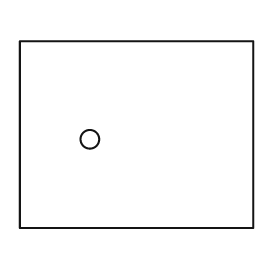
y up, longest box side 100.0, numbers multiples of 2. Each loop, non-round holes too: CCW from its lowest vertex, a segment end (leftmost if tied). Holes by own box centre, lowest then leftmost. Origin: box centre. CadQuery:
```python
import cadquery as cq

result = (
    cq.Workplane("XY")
    .moveTo(-50.0, -40.0)
    .lineTo(50.0, -40.0)
    .lineTo(50.0, 40.0)
    .lineTo(-50.0, 40.0)
    .close()
    .moveTo(-20.0, -2.0)
    .circle(4.0)
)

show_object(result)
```